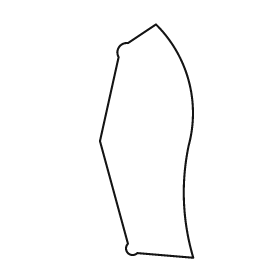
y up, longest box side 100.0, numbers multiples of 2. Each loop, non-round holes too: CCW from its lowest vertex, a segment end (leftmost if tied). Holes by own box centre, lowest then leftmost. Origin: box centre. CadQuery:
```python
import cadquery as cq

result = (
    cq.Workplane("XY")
    .moveTo(20.0, -50.0)
    .threePointArc((16.0, -26.0), (18.0, -2.0))
    .threePointArc((18.0, 26.0), (4.0, 50.0))
    .lineTo(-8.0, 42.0)
    .threePointArc((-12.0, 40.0), (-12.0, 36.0))
    .lineTo(-20.0, 0.0)
    .lineTo(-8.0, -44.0)
    .threePointArc((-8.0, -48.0), (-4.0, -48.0))
    .close()
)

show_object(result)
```